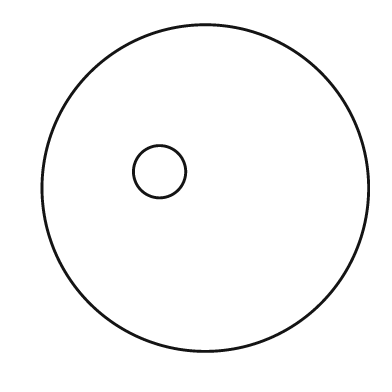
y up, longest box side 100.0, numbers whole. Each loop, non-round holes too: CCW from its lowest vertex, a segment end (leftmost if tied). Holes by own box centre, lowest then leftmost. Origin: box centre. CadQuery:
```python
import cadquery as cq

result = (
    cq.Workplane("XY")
    .moveTo(0.0, 0.0)
    .circle(50.0)
    .moveTo(-14.0, 5.0)
    .circle(8.0)
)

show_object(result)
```